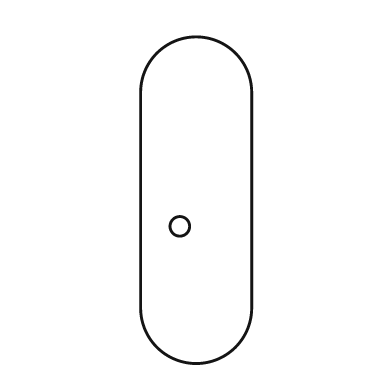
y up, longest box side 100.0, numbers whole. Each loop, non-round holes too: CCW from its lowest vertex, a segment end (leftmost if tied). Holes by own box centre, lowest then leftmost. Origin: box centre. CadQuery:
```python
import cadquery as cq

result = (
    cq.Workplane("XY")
    .moveTo(-17.0, -33.0)
    .threePointArc((0.0, -50.0), (17.0, -33.0))
    .lineTo(17.0, 33.0)
    .threePointArc((0.0, 50.0), (-17.0, 33.0))
    .close()
    .moveTo(-5.0, -8.0)
    .circle(3.0)
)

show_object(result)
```